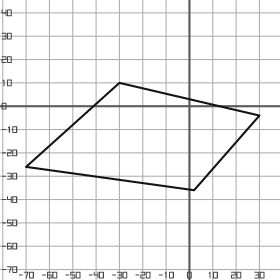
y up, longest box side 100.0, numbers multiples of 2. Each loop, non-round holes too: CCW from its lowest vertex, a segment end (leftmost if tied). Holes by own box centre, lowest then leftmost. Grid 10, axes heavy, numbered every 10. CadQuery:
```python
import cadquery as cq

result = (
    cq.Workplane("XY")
    .moveTo(2.0, -36.0)
    .lineTo(30.0, -4.0)
    .lineTo(-30.0, 10.0)
    .lineTo(-70.0, -26.0)
    .close()
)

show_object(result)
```